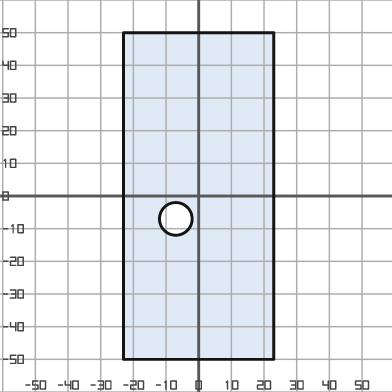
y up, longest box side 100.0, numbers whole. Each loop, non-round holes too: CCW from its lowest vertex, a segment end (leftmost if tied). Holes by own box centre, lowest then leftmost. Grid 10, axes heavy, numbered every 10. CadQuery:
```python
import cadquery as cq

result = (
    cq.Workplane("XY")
    .moveTo(-23.0, -50.0)
    .lineTo(23.0, -50.0)
    .lineTo(23.0, 50.0)
    .lineTo(-23.0, 50.0)
    .close()
    .moveTo(-7.0, -7.0)
    .circle(5.0)
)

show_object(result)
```